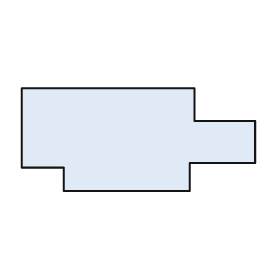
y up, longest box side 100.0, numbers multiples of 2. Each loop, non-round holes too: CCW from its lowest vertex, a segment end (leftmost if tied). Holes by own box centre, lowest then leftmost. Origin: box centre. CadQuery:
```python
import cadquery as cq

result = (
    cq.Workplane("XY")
    .moveTo(-32.0, -22.0)
    .lineTo(22.0, -22.0)
    .lineTo(22.0, -10.0)
    .lineTo(50.0, -10.0)
    .lineTo(50.0, 8.0)
    .lineTo(24.0, 8.0)
    .lineTo(24.0, 22.0)
    .lineTo(-50.0, 22.0)
    .lineTo(-50.0, -12.0)
    .lineTo(-32.0, -12.0)
    .close()
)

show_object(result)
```